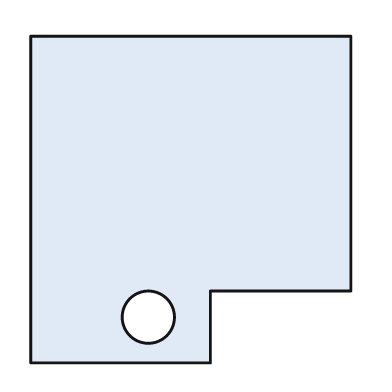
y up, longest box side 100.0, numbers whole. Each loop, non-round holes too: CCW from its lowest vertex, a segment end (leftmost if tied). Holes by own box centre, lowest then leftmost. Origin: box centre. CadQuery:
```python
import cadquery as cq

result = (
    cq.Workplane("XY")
    .moveTo(-49.0, -50.0)
    .lineTo(6.0, -50.0)
    .lineTo(6.0, -28.0)
    .lineTo(49.0, -28.0)
    .lineTo(49.0, 50.0)
    .lineTo(-49.0, 50.0)
    .close()
    .moveTo(-13.0, -36.0)
    .circle(8.0)
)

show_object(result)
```